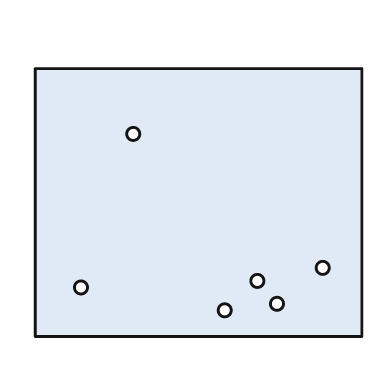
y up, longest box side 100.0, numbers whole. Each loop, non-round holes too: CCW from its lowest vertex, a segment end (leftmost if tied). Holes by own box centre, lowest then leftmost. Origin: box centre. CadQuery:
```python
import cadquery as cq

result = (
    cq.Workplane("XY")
    .moveTo(-50.0, -41.0)
    .lineTo(50.0, -41.0)
    .lineTo(50.0, 41.0)
    .lineTo(-50.0, 41.0)
    .close()
    .moveTo(8.0, -33.0)
    .circle(2.0)
    .moveTo(24.0, -31.0)
    .circle(2.0)
    .moveTo(-36.0, -26.0)
    .circle(2.0)
    .moveTo(18.0, -24.0)
    .circle(2.0)
    .moveTo(38.0, -20.0)
    .circle(2.0)
    .moveTo(-20.0, 21.0)
    .circle(2.0)
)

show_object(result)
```